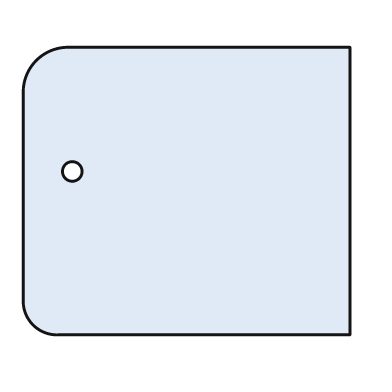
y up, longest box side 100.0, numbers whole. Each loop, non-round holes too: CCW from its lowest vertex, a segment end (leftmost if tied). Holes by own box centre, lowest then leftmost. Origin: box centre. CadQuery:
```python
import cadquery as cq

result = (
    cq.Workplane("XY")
    .moveTo(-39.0, -44.0)
    .lineTo(50.0, -44.0)
    .lineTo(50.0, 44.0)
    .lineTo(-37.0, 44.0)
    .threePointArc((-46.0, 40.0), (-50.0, 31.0))
    .lineTo(-50.0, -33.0)
    .threePointArc((-47.0, -41.0), (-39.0, -44.0))
    .close()
    .moveTo(-35.0, 6.0)
    .circle(3.0)
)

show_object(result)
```